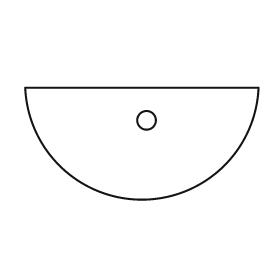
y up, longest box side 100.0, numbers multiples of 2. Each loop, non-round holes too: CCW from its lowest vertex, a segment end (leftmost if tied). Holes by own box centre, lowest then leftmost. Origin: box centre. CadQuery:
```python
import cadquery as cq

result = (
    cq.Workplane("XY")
    .moveTo(-50.0, 24.0)
    .threePointArc((0.0, -24.0), (50.0, 24.0))
    .close()
    .moveTo(2.0, 10.0)
    .circle(4.0)
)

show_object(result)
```